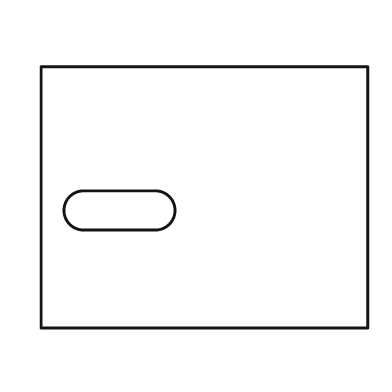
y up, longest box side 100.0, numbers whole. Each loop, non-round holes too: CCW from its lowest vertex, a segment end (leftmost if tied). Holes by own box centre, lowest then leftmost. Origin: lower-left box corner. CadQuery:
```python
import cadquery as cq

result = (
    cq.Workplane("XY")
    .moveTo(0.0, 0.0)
    .lineTo(100.0, 0.0)
    .lineTo(100.0, 80.0)
    .lineTo(0.0, 80.0)
    .close()
    .moveTo(13.0, 30.0)
    .lineTo(35.0, 30.0)
    .threePointArc((41.0, 36.0), (35.0, 42.0))
    .lineTo(13.0, 42.0)
    .threePointArc((7.0, 36.0), (13.0, 30.0))
    .close()
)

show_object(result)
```